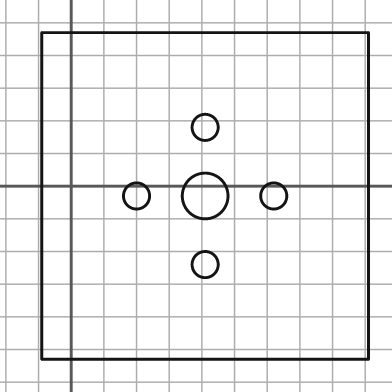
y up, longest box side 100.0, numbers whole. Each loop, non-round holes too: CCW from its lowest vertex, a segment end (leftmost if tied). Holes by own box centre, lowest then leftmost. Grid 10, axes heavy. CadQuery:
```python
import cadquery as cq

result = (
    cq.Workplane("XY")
    .moveTo(-9.0, -53.0)
    .lineTo(91.0, -53.0)
    .lineTo(91.0, 47.0)
    .lineTo(-9.0, 47.0)
    .close()
    .moveTo(41.0, -24.0)
    .circle(4.0)
    .moveTo(20.0, -3.0)
    .circle(4.0)
    .moveTo(41.0, -3.0)
    .circle(7.0)
    .moveTo(62.0, -3.0)
    .circle(4.0)
    .moveTo(41.0, 18.0)
    .circle(4.0)
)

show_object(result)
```